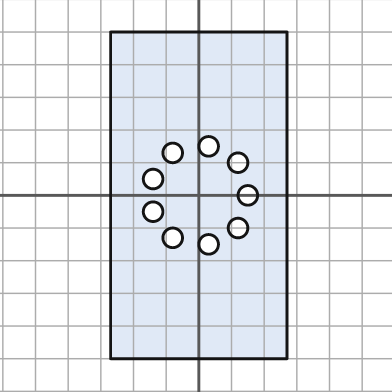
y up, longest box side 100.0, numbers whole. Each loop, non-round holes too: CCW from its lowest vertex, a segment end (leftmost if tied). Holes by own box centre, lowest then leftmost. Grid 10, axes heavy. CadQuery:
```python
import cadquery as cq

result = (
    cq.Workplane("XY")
    .moveTo(-27.0, -50.0)
    .lineTo(27.0, -50.0)
    .lineTo(27.0, 50.0)
    .lineTo(-27.0, 50.0)
    .close()
    .moveTo(3.0, -15.0)
    .circle(3.0)
    .moveTo(-8.0, -13.0)
    .circle(3.0)
    .moveTo(12.0, -10.0)
    .circle(3.0)
    .moveTo(-14.0, -5.0)
    .circle(3.0)
    .moveTo(15.0, 0.0)
    .circle(3.0)
    .moveTo(-14.0, 5.0)
    .circle(3.0)
    .moveTo(12.0, 10.0)
    .circle(3.0)
    .moveTo(-8.0, 13.0)
    .circle(3.0)
    .moveTo(3.0, 15.0)
    .circle(3.0)
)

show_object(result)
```